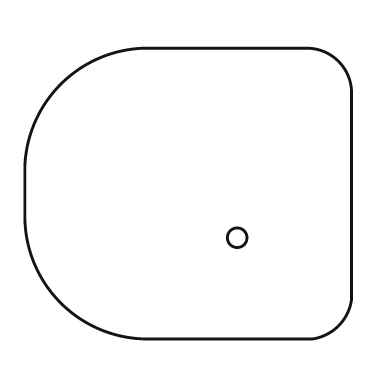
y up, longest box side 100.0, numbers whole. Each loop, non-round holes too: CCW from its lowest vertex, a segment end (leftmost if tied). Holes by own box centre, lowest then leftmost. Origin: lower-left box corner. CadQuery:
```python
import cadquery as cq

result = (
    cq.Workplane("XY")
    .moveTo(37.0, 0.0)
    .lineTo(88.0, 0.0)
    .threePointArc((96.0, 4.0), (100.0, 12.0))
    .lineTo(100.0, 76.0)
    .threePointArc((96.0, 85.0), (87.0, 89.0))
    .lineTo(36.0, 89.0)
    .threePointArc((11.0, 78.0), (0.0, 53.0))
    .lineTo(0.0, 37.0)
    .threePointArc((11.0, 11.0), (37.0, 0.0))
    .close()
    .moveTo(65.0, 31.0)
    .circle(3.0)
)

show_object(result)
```